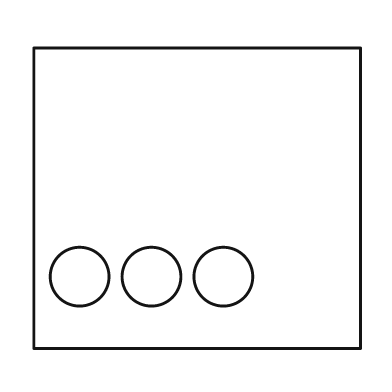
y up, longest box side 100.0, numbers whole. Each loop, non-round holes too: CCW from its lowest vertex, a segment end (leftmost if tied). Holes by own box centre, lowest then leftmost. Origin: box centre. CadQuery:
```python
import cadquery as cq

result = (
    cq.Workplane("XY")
    .moveTo(-50.0, -46.0)
    .lineTo(50.0, -46.0)
    .lineTo(50.0, 46.0)
    .lineTo(-50.0, 46.0)
    .close()
    .moveTo(-36.0, -24.0)
    .circle(9.0)
    .moveTo(-14.0, -24.0)
    .circle(9.0)
    .moveTo(8.0, -24.0)
    .circle(9.0)
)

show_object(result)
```